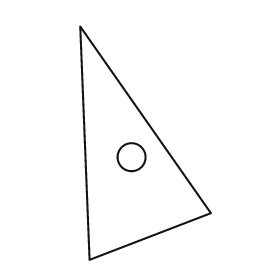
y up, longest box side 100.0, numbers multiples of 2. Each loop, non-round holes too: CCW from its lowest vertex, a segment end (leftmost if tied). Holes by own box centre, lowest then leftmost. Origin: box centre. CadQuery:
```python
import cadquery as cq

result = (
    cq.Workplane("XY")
    .moveTo(-24.0, -50.0)
    .lineTo(28.0, -30.0)
    .lineTo(-28.0, 50.0)
    .close()
    .moveTo(-6.0, -6.0)
    .circle(6.0)
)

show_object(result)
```